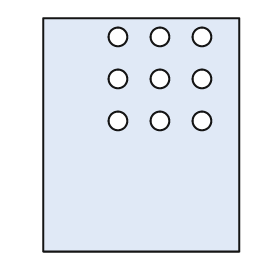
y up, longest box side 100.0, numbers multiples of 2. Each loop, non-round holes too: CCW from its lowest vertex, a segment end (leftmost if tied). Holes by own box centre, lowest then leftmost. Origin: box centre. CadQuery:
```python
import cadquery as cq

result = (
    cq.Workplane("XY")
    .moveTo(-42.0, -50.0)
    .lineTo(42.0, -50.0)
    .lineTo(42.0, 50.0)
    .lineTo(-42.0, 50.0)
    .close()
    .moveTo(-10.0, 6.0)
    .circle(4.0)
    .moveTo(8.0, 6.0)
    .circle(4.0)
    .moveTo(26.0, 6.0)
    .circle(4.0)
    .moveTo(-10.0, 24.0)
    .circle(4.0)
    .moveTo(8.0, 24.0)
    .circle(4.0)
    .moveTo(26.0, 24.0)
    .circle(4.0)
    .moveTo(-10.0, 42.0)
    .circle(4.0)
    .moveTo(8.0, 42.0)
    .circle(4.0)
    .moveTo(26.0, 42.0)
    .circle(4.0)
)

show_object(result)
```